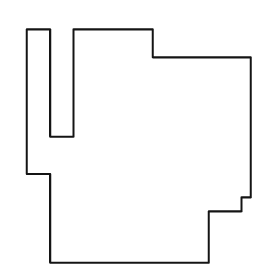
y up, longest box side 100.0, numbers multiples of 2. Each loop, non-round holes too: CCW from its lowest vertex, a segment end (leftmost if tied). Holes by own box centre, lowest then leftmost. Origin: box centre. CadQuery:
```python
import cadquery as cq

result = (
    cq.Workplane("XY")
    .moveTo(-38.0, -50.0)
    .lineTo(30.0, -50.0)
    .lineTo(30.0, -28.0)
    .lineTo(44.0, -28.0)
    .lineTo(44.0, -22.0)
    .lineTo(48.0, -22.0)
    .lineTo(48.0, 38.0)
    .lineTo(6.0, 38.0)
    .lineTo(6.0, 50.0)
    .lineTo(-28.0, 50.0)
    .lineTo(-28.0, 4.0)
    .lineTo(-38.0, 4.0)
    .lineTo(-38.0, 50.0)
    .lineTo(-48.0, 50.0)
    .lineTo(-48.0, -12.0)
    .lineTo(-38.0, -12.0)
    .close()
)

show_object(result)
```